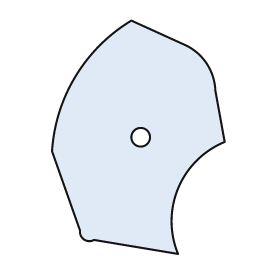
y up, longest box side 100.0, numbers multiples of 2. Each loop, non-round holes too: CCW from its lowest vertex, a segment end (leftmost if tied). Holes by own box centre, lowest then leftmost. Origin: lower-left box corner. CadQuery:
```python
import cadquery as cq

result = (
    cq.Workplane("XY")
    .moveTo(54.0, 0.0)
    .threePointArc((54.0, 28.0), (74.0, 48.0))
    .lineTo(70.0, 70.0)
    .threePointArc((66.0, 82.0), (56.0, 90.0))
    .lineTo(34.0, 100.0)
    .threePointArc((10.0, 76.0), (0.0, 44.0))
    .lineTo(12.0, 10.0)
    .threePointArc((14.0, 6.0), (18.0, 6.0))
    .close()
    .moveTo(38.0, 50.0)
    .circle(4.0)
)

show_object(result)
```